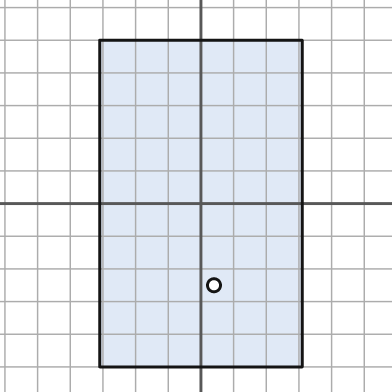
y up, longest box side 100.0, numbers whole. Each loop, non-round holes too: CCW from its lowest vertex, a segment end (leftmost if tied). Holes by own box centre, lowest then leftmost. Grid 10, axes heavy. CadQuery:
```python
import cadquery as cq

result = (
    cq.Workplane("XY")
    .moveTo(-31.0, -50.0)
    .lineTo(31.0, -50.0)
    .lineTo(31.0, 50.0)
    .lineTo(-31.0, 50.0)
    .close()
    .moveTo(4.0, -25.0)
    .circle(2.0)
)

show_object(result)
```